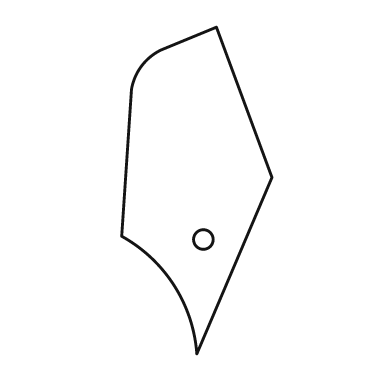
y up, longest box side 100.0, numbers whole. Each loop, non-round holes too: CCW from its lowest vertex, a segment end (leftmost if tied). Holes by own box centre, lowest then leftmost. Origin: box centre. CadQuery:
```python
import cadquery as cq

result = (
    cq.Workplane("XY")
    .moveTo(0.0, -50.0)
    .lineTo(23.0, 4.0)
    .lineTo(6.0, 50.0)
    .lineTo(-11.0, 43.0)
    .threePointArc((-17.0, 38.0), (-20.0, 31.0))
    .lineTo(-23.0, -14.0)
    .threePointArc((-7.0, -29.0), (0.0, -50.0))
    .close()
    .moveTo(2.0, -15.0)
    .circle(3.0)
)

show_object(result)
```